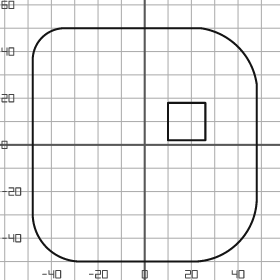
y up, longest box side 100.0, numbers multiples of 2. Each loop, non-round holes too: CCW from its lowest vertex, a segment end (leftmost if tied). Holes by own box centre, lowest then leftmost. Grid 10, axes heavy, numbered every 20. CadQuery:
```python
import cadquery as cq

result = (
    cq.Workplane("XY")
    .moveTo(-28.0, -50.0)
    .lineTo(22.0, -50.0)
    .threePointArc((40.0, -42.0), (48.0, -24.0))
    .lineTo(48.0, 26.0)
    .threePointArc((40.0, 42.0), (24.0, 50.0))
    .lineTo(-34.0, 50.0)
    .threePointArc((-44.0, 46.0), (-48.0, 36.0))
    .lineTo(-48.0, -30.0)
    .threePointArc((-42.0, -44.0), (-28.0, -50.0))
    .close()
    .moveTo(10.0, 2.0)
    .lineTo(26.0, 2.0)
    .lineTo(26.0, 18.0)
    .lineTo(10.0, 18.0)
    .close()
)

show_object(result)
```